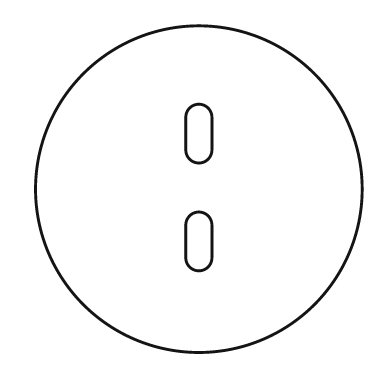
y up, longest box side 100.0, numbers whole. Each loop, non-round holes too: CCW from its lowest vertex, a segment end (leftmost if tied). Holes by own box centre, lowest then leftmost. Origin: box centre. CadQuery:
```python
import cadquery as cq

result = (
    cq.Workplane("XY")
    .moveTo(0.0, 0.0)
    .circle(50.0)
    .moveTo(-4.0, -21.0)
    .threePointArc((0.0, -25.0), (4.0, -21.0))
    .lineTo(4.0, -11.0)
    .threePointArc((0.0, -7.0), (-4.0, -11.0))
    .close()
    .moveTo(-4.0, 12.0)
    .threePointArc((0.0, 8.0), (4.0, 12.0))
    .lineTo(4.0, 22.0)
    .threePointArc((0.0, 26.0), (-4.0, 22.0))
    .close()
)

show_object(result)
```